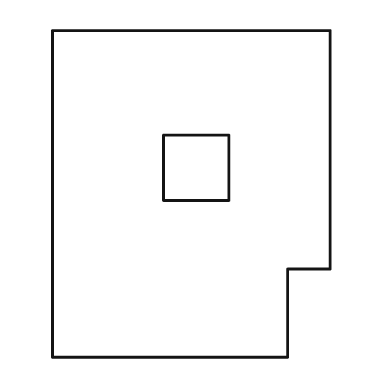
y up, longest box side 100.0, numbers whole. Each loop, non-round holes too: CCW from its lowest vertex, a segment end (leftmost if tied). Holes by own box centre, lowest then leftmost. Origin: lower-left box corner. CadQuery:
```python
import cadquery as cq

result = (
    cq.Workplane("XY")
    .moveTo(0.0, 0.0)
    .lineTo(72.0, 0.0)
    .lineTo(72.0, 27.0)
    .lineTo(85.0, 27.0)
    .lineTo(85.0, 100.0)
    .lineTo(0.0, 100.0)
    .close()
    .moveTo(34.0, 48.0)
    .lineTo(54.0, 48.0)
    .lineTo(54.0, 68.0)
    .lineTo(34.0, 68.0)
    .close()
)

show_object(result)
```